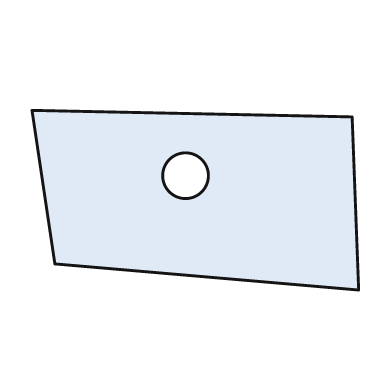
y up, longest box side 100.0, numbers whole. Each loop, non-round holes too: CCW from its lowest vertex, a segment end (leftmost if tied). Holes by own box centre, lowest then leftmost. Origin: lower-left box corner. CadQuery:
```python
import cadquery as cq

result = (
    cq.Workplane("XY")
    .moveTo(100.0, 0.0)
    .lineTo(98.0, 53.0)
    .lineTo(0.0, 55.0)
    .lineTo(7.0, 8.0)
    .close()
    .moveTo(47.0, 35.0)
    .circle(7.0)
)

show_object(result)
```